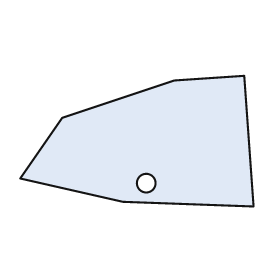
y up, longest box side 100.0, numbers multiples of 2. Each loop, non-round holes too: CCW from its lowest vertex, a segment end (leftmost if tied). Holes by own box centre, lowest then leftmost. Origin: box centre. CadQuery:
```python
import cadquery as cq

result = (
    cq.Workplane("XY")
    .moveTo(50.0, -28.0)
    .lineTo(46.0, 28.0)
    .lineTo(16.0, 26.0)
    .lineTo(-32.0, 10.0)
    .lineTo(-50.0, -16.0)
    .lineTo(-6.0, -26.0)
    .close()
    .moveTo(4.0, -18.0)
    .circle(4.0)
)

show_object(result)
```